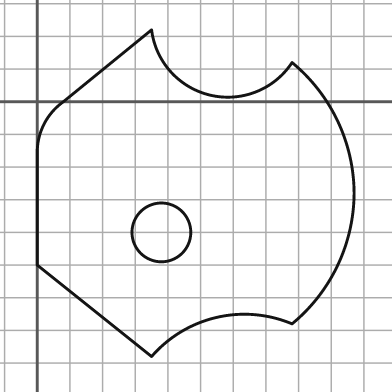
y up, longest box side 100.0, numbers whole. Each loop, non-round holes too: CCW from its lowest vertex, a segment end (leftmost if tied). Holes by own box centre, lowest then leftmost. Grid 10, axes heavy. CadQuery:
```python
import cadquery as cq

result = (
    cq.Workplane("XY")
    .moveTo(35.0, -78.0)
    .threePointArc((55.0, -66.0), (78.0, -68.0))
    .threePointArc((92.0, -50.0), (97.0, -28.0))
    .threePointArc((92.0, -6.0), (78.0, 12.0))
    .threePointArc((53.0, 2.0), (35.0, 22.0))
    .lineTo(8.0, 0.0)
    .threePointArc((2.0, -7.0), (0.0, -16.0))
    .lineTo(0.0, -50.0)
    .close()
    .moveTo(38.0, -40.0)
    .circle(9.0)
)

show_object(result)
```